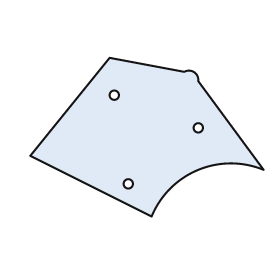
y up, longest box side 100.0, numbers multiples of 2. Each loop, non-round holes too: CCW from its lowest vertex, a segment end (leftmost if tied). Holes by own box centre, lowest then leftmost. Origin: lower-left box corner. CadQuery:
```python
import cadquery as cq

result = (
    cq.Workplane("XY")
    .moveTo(52.0, 0.0)
    .threePointArc((72.0, 20.0), (100.0, 20.0))
    .lineTo(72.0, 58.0)
    .threePointArc((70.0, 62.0), (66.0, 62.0))
    .lineTo(34.0, 68.0)
    .lineTo(0.0, 26.0)
    .close()
    .moveTo(42.0, 14.0)
    .circle(2.0)
    .moveTo(72.0, 38.0)
    .circle(2.0)
    .moveTo(36.0, 52.0)
    .circle(2.0)
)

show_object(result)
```